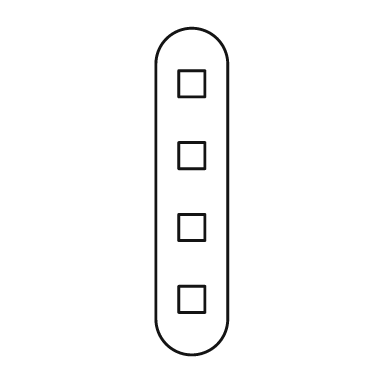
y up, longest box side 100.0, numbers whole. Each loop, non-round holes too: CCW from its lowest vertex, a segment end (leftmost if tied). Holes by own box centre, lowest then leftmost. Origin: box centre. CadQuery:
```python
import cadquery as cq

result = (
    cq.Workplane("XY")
    .moveTo(-11.0, -39.0)
    .threePointArc((0.0, -50.0), (11.0, -39.0))
    .lineTo(11.0, 39.0)
    .threePointArc((0.0, 50.0), (-11.0, 39.0))
    .close()
    .moveTo(-4.0, -37.0)
    .lineTo(4.0, -37.0)
    .lineTo(4.0, -29.0)
    .lineTo(-4.0, -29.0)
    .close()
    .moveTo(-4.0, -15.0)
    .lineTo(4.0, -15.0)
    .lineTo(4.0, -7.0)
    .lineTo(-4.0, -7.0)
    .close()
    .moveTo(-4.0, 7.0)
    .lineTo(4.0, 7.0)
    .lineTo(4.0, 15.0)
    .lineTo(-4.0, 15.0)
    .close()
    .moveTo(-4.0, 29.0)
    .lineTo(4.0, 29.0)
    .lineTo(4.0, 37.0)
    .lineTo(-4.0, 37.0)
    .close()
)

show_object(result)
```